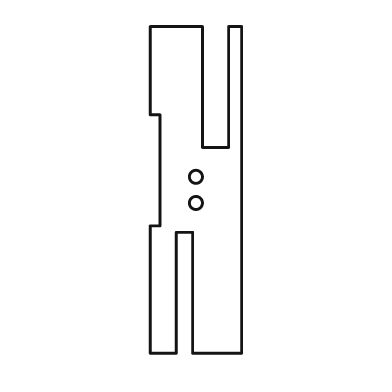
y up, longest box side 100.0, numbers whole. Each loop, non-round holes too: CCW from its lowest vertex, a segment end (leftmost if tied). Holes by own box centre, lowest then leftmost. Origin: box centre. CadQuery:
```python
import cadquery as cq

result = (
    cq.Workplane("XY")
    .moveTo(-14.0, -50.0)
    .lineTo(-6.0, -50.0)
    .lineTo(-6.0, -13.0)
    .lineTo(-1.0, -13.0)
    .lineTo(-1.0, -50.0)
    .lineTo(14.0, -50.0)
    .lineTo(14.0, 50.0)
    .lineTo(10.0, 50.0)
    .lineTo(10.0, 13.0)
    .lineTo(2.0, 13.0)
    .lineTo(2.0, 50.0)
    .lineTo(-14.0, 50.0)
    .lineTo(-14.0, 23.0)
    .lineTo(-11.0, 23.0)
    .lineTo(-11.0, -11.0)
    .lineTo(-14.0, -11.0)
    .close()
    .moveTo(0.0, -4.0)
    .circle(2.0)
    .moveTo(0.0, 4.0)
    .circle(2.0)
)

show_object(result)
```